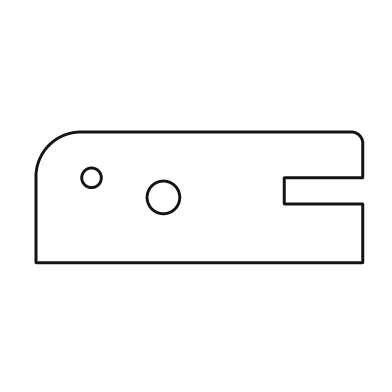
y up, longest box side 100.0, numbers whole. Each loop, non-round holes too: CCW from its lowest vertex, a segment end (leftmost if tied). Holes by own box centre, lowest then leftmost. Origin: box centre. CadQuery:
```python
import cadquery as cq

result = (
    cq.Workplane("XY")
    .moveTo(-50.0, -20.0)
    .lineTo(50.0, -20.0)
    .lineTo(50.0, -2.0)
    .lineTo(26.0, -2.0)
    .lineTo(26.0, 6.0)
    .lineTo(50.0, 6.0)
    .lineTo(50.0, 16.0)
    .threePointArc((49.0, 19.0), (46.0, 20.0))
    .lineTo(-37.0, 20.0)
    .threePointArc((-46.0, 16.0), (-50.0, 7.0))
    .close()
    .moveTo(-11.0, 0.0)
    .circle(5.0)
    .moveTo(-33.0, 6.0)
    .circle(3.0)
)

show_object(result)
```